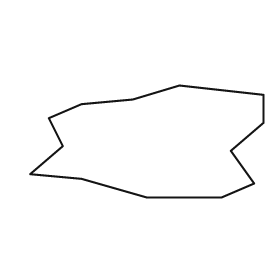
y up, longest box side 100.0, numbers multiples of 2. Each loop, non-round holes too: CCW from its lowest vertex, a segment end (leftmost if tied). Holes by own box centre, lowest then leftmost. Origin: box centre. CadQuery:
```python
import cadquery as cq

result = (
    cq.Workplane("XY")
    .moveTo(0.0, -24.0)
    .lineTo(32.0, -24.0)
    .lineTo(46.0, -18.0)
    .lineTo(36.0, -4.0)
    .lineTo(50.0, 8.0)
    .lineTo(50.0, 20.0)
    .lineTo(14.0, 24.0)
    .lineTo(-6.0, 18.0)
    .lineTo(-28.0, 16.0)
    .lineTo(-42.0, 10.0)
    .lineTo(-36.0, -2.0)
    .lineTo(-50.0, -14.0)
    .lineTo(-28.0, -16.0)
    .close()
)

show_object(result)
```